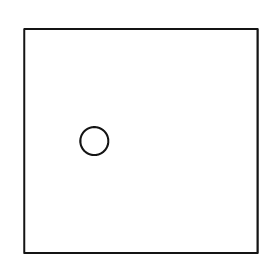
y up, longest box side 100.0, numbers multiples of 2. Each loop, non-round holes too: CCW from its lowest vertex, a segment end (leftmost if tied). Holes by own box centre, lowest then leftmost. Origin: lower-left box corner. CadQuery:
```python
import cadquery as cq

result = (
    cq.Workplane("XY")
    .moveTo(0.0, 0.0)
    .lineTo(100.0, 0.0)
    .lineTo(100.0, 96.0)
    .lineTo(0.0, 96.0)
    .close()
    .moveTo(30.0, 48.0)
    .circle(6.0)
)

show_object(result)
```